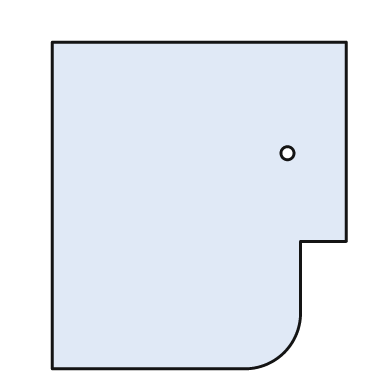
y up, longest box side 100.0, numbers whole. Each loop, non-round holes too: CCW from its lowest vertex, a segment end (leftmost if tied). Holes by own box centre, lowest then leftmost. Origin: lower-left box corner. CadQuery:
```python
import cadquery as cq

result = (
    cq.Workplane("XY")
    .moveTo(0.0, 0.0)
    .lineTo(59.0, 0.0)
    .threePointArc((71.0, 5.0), (76.0, 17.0))
    .lineTo(76.0, 39.0)
    .lineTo(90.0, 39.0)
    .lineTo(90.0, 100.0)
    .lineTo(0.0, 100.0)
    .close()
    .moveTo(72.0, 66.0)
    .circle(2.0)
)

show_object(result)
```